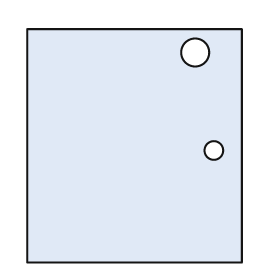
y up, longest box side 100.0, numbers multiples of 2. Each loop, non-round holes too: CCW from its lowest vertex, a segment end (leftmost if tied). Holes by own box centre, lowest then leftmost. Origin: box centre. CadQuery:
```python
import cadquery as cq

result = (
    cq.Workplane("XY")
    .moveTo(-46.0, -50.0)
    .lineTo(46.0, -50.0)
    .lineTo(46.0, 50.0)
    .lineTo(-46.0, 50.0)
    .close()
    .moveTo(34.0, -2.0)
    .circle(4.0)
    .moveTo(26.0, 40.0)
    .circle(6.0)
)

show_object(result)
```